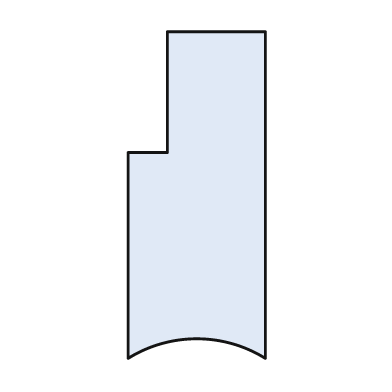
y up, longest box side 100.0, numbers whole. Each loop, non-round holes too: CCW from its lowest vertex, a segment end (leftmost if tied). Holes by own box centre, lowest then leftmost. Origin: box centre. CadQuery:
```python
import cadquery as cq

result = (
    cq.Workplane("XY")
    .moveTo(-21.0, -50.0)
    .threePointArc((0.0, -44.0), (21.0, -50.0))
    .lineTo(21.0, 50.0)
    .lineTo(-9.0, 50.0)
    .lineTo(-9.0, 13.0)
    .lineTo(-21.0, 13.0)
    .close()
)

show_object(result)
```